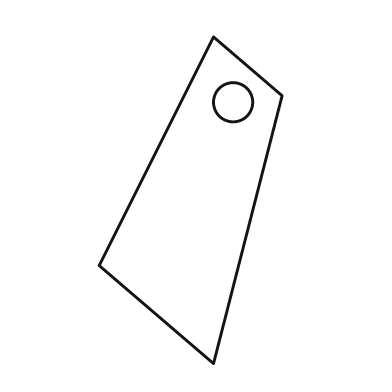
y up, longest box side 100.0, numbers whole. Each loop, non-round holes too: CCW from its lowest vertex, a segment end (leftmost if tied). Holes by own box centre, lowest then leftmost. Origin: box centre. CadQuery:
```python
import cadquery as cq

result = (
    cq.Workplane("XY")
    .moveTo(7.0, -50.0)
    .lineTo(28.0, 32.0)
    .lineTo(7.0, 50.0)
    .lineTo(-28.0, -20.0)
    .close()
    .moveTo(13.0, 30.0)
    .circle(6.0)
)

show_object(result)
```